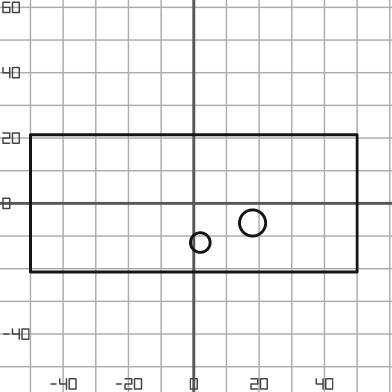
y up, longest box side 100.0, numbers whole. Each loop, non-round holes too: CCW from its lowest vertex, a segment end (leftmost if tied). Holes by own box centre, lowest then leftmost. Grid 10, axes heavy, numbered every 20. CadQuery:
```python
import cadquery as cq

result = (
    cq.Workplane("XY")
    .moveTo(-50.0, -21.0)
    .lineTo(50.0, -21.0)
    .lineTo(50.0, 21.0)
    .lineTo(-50.0, 21.0)
    .close()
    .moveTo(2.0, -12.0)
    .circle(3.0)
    .moveTo(18.0, -6.0)
    .circle(4.0)
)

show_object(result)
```